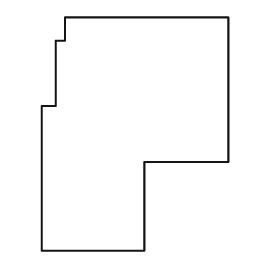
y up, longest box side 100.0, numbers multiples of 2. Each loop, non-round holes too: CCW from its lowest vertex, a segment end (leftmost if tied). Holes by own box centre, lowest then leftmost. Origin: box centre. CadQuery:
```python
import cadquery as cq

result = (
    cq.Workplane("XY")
    .moveTo(-40.0, -50.0)
    .lineTo(4.0, -50.0)
    .lineTo(4.0, -12.0)
    .lineTo(40.0, -12.0)
    .lineTo(40.0, 50.0)
    .lineTo(-30.0, 50.0)
    .lineTo(-30.0, 40.0)
    .lineTo(-34.0, 40.0)
    .lineTo(-34.0, 12.0)
    .lineTo(-40.0, 12.0)
    .close()
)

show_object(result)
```